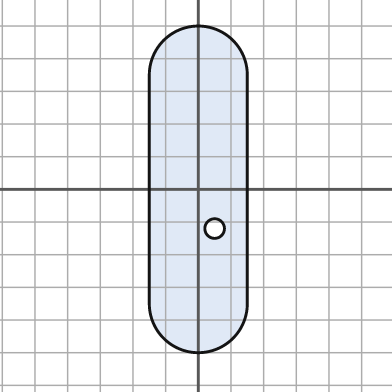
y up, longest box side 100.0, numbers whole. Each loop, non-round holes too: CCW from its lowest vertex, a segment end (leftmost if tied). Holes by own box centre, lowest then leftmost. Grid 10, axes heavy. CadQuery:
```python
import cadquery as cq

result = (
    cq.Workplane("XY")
    .moveTo(-15.0, -35.0)
    .threePointArc((0.0, -50.0), (15.0, -35.0))
    .lineTo(15.0, 35.0)
    .threePointArc((0.0, 50.0), (-15.0, 35.0))
    .close()
    .moveTo(5.0, -12.0)
    .circle(3.0)
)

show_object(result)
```